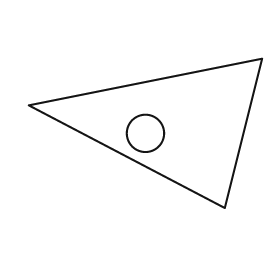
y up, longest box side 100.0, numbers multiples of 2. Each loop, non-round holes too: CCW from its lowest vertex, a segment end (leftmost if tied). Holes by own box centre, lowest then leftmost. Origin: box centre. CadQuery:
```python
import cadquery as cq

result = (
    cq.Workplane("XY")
    .moveTo(34.0, -32.0)
    .lineTo(50.0, 32.0)
    .lineTo(-50.0, 12.0)
    .close()
    .moveTo(0.0, 0.0)
    .circle(8.0)
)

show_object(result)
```